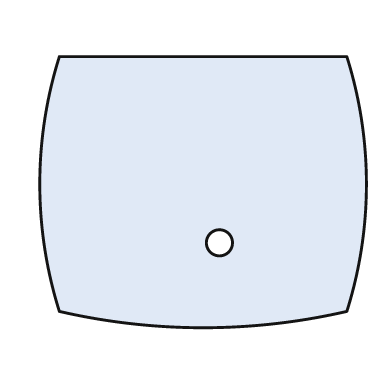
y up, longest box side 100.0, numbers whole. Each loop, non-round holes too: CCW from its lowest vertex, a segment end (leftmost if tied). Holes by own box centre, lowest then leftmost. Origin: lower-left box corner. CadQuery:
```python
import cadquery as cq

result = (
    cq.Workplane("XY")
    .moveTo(6.0, 5.0)
    .threePointArc((50.0, 0.0), (94.0, 5.0))
    .threePointArc((100.0, 44.0), (94.0, 83.0))
    .lineTo(6.0, 83.0)
    .threePointArc((0.0, 44.0), (6.0, 5.0))
    .close()
    .moveTo(55.0, 26.0)
    .circle(4.0)
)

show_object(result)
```